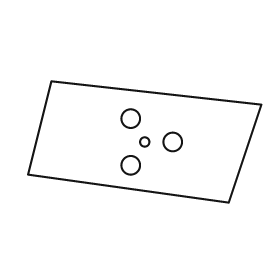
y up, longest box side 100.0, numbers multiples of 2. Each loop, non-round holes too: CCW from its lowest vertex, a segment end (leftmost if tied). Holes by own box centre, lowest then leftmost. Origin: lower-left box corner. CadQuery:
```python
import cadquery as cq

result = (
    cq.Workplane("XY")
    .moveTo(86.0, 0.0)
    .lineTo(100.0, 42.0)
    .lineTo(10.0, 52.0)
    .lineTo(0.0, 12.0)
    .close()
    .moveTo(44.0, 16.0)
    .circle(4.0)
    .moveTo(50.0, 26.0)
    .circle(2.0)
    .moveTo(62.0, 26.0)
    .circle(4.0)
    .moveTo(44.0, 36.0)
    .circle(4.0)
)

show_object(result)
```